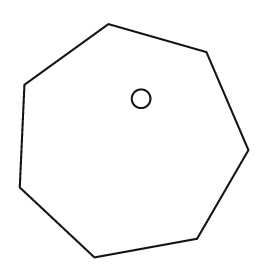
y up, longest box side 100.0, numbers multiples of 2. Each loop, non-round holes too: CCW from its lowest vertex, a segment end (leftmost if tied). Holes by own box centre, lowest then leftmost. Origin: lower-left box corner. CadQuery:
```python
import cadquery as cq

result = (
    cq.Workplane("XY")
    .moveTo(32.0, 0.0)
    .lineTo(76.0, 8.0)
    .lineTo(98.0, 46.0)
    .lineTo(80.0, 88.0)
    .lineTo(38.0, 100.0)
    .lineTo(2.0, 74.0)
    .lineTo(0.0, 30.0)
    .close()
    .moveTo(52.0, 68.0)
    .circle(4.0)
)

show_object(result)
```